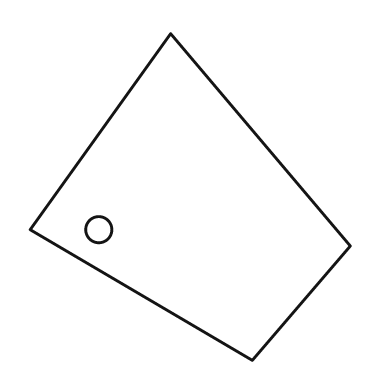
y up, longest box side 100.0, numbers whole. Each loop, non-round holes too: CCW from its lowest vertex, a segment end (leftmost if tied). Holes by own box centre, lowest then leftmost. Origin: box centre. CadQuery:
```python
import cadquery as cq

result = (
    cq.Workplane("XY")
    .moveTo(19.0, -50.0)
    .lineTo(49.0, -15.0)
    .lineTo(-6.0, 50.0)
    .lineTo(-49.0, -10.0)
    .close()
    .moveTo(-28.0, -10.0)
    .circle(4.0)
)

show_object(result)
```